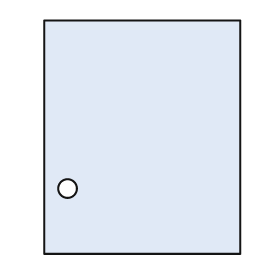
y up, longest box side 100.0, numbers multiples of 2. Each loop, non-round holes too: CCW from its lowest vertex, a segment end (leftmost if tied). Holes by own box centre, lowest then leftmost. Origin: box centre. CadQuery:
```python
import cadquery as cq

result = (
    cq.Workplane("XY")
    .moveTo(-42.0, -50.0)
    .lineTo(42.0, -50.0)
    .lineTo(42.0, 50.0)
    .lineTo(-42.0, 50.0)
    .close()
    .moveTo(-32.0, -22.0)
    .circle(4.0)
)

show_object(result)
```